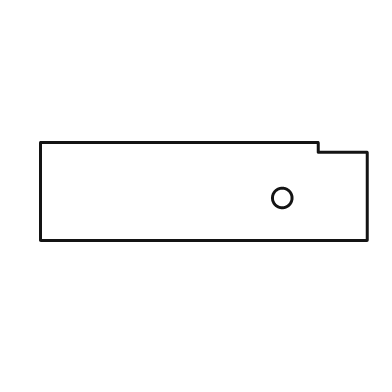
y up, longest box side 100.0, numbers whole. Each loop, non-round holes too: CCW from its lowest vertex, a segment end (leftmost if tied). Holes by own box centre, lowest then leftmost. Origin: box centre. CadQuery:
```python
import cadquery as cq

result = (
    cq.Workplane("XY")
    .moveTo(-50.0, -15.0)
    .lineTo(50.0, -15.0)
    .lineTo(50.0, 12.0)
    .lineTo(35.0, 12.0)
    .lineTo(35.0, 15.0)
    .lineTo(-50.0, 15.0)
    .close()
    .moveTo(24.0, -2.0)
    .circle(3.0)
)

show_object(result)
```